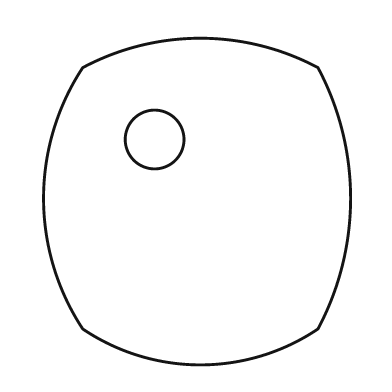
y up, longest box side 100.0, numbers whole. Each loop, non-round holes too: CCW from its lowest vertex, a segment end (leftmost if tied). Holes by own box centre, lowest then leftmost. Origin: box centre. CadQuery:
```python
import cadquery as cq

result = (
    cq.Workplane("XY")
    .moveTo(-35.0, -39.0)
    .threePointArc((1.0, -50.0), (37.0, -39.0))
    .threePointArc((47.0, 1.0), (37.0, 41.0))
    .threePointArc((1.0, 50.0), (-35.0, 41.0))
    .threePointArc((-47.0, 1.0), (-35.0, -39.0))
    .close()
    .moveTo(-13.0, 19.0)
    .circle(9.0)
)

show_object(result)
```